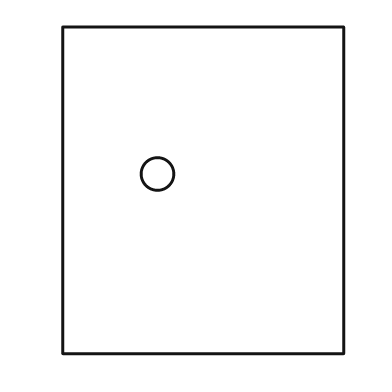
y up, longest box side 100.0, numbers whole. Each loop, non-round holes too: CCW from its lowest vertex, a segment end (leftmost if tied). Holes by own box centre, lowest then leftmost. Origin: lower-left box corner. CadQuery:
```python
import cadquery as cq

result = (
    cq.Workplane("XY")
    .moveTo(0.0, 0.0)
    .lineTo(86.0, 0.0)
    .lineTo(86.0, 100.0)
    .lineTo(0.0, 100.0)
    .close()
    .moveTo(29.0, 55.0)
    .circle(5.0)
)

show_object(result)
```